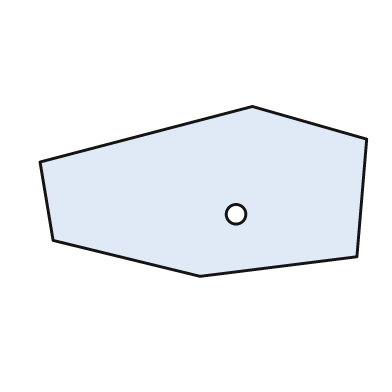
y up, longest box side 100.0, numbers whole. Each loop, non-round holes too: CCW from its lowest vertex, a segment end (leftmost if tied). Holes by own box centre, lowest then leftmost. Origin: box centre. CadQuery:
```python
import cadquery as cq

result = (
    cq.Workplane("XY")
    .moveTo(-1.0, -26.0)
    .lineTo(47.0, -20.0)
    .lineTo(50.0, 16.0)
    .lineTo(15.0, 26.0)
    .lineTo(-50.0, 9.0)
    .lineTo(-46.0, -15.0)
    .close()
    .moveTo(10.0, -7.0)
    .circle(3.0)
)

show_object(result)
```